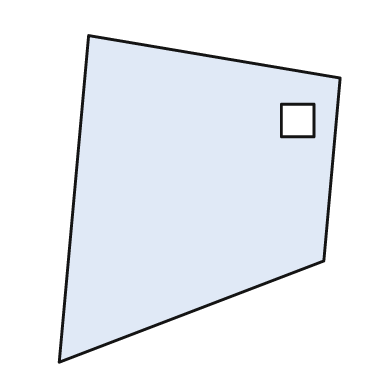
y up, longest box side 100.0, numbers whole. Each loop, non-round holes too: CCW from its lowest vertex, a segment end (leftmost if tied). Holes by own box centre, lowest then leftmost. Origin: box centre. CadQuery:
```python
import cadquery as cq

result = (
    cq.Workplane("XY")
    .moveTo(-43.0, -50.0)
    .lineTo(38.0, -19.0)
    .lineTo(43.0, 37.0)
    .lineTo(-34.0, 50.0)
    .close()
    .moveTo(25.0, 19.0)
    .lineTo(35.0, 19.0)
    .lineTo(35.0, 29.0)
    .lineTo(25.0, 29.0)
    .close()
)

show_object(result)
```